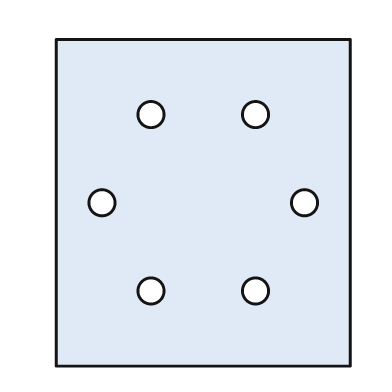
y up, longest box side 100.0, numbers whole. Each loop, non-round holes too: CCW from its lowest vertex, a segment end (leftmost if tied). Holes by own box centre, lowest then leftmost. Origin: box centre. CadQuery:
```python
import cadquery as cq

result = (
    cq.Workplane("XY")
    .moveTo(-45.0, -50.0)
    .lineTo(45.0, -50.0)
    .lineTo(45.0, 50.0)
    .lineTo(-45.0, 50.0)
    .close()
    .moveTo(-16.0, -27.0)
    .circle(4.0)
    .moveTo(16.0, -27.0)
    .circle(4.0)
    .moveTo(-31.0, 0.0)
    .circle(4.0)
    .moveTo(31.0, 0.0)
    .circle(4.0)
    .moveTo(-16.0, 27.0)
    .circle(4.0)
    .moveTo(16.0, 27.0)
    .circle(4.0)
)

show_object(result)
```